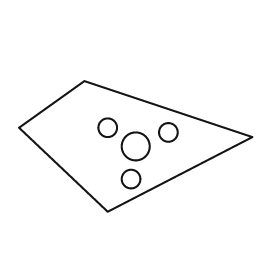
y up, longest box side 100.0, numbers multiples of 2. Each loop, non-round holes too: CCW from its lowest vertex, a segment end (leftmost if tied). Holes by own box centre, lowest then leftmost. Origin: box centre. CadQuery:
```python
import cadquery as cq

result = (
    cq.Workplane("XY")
    .moveTo(-12.0, -28.0)
    .lineTo(50.0, 4.0)
    .lineTo(-22.0, 28.0)
    .lineTo(-50.0, 8.0)
    .close()
    .moveTo(-2.0, -14.0)
    .circle(4.0)
    .moveTo(0.0, 0.0)
    .circle(6.0)
    .moveTo(14.0, 6.0)
    .circle(4.0)
    .moveTo(-12.0, 8.0)
    .circle(4.0)
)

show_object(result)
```